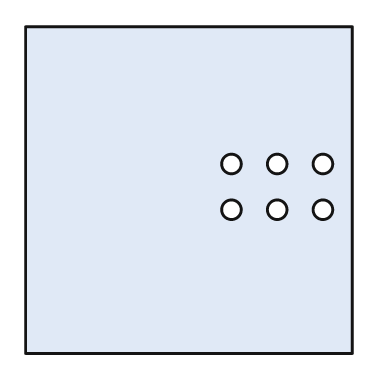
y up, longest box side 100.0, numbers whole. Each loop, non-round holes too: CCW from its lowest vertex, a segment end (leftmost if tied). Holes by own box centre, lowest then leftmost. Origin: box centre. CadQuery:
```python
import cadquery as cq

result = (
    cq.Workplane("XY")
    .moveTo(-50.0, -50.0)
    .lineTo(50.0, -50.0)
    .lineTo(50.0, 50.0)
    .lineTo(-50.0, 50.0)
    .close()
    .moveTo(13.0, -6.0)
    .circle(3.0)
    .moveTo(27.0, -6.0)
    .circle(3.0)
    .moveTo(41.0, -6.0)
    .circle(3.0)
    .moveTo(13.0, 8.0)
    .circle(3.0)
    .moveTo(27.0, 8.0)
    .circle(3.0)
    .moveTo(41.0, 8.0)
    .circle(3.0)
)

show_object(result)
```